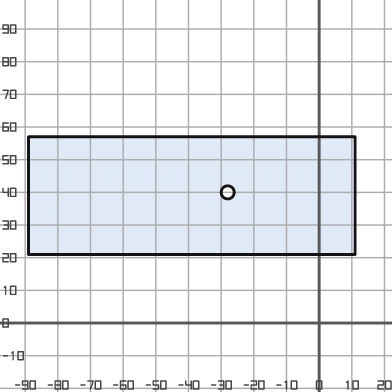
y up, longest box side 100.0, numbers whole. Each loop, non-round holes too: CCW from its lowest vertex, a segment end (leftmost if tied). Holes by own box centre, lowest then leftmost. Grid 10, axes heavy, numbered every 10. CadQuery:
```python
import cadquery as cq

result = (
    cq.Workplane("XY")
    .moveTo(-89.0, 21.0)
    .lineTo(11.0, 21.0)
    .lineTo(11.0, 57.0)
    .lineTo(-89.0, 57.0)
    .close()
    .moveTo(-28.0, 40.0)
    .circle(2.0)
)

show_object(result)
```